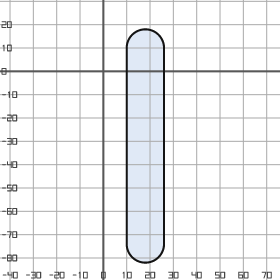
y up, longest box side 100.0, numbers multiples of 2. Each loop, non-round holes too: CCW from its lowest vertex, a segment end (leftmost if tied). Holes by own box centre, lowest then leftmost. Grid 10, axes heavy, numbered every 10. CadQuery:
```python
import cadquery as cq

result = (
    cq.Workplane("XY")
    .moveTo(10.0, -74.0)
    .threePointArc((18.0, -82.0), (26.0, -74.0))
    .lineTo(26.0, 10.0)
    .threePointArc((18.0, 18.0), (10.0, 10.0))
    .close()
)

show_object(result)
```